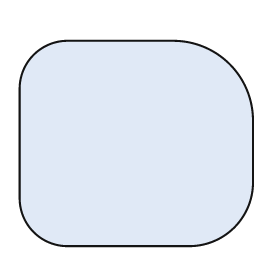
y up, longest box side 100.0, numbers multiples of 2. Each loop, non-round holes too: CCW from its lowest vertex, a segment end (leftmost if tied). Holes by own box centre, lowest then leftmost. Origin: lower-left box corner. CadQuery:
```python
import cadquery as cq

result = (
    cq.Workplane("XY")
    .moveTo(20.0, 0.0)
    .lineTo(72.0, 0.0)
    .threePointArc((92.0, 8.0), (100.0, 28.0))
    .lineTo(100.0, 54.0)
    .threePointArc((90.0, 78.0), (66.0, 88.0))
    .lineTo(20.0, 88.0)
    .threePointArc((6.0, 82.0), (0.0, 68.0))
    .lineTo(0.0, 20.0)
    .threePointArc((6.0, 6.0), (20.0, 0.0))
    .close()
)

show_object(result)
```